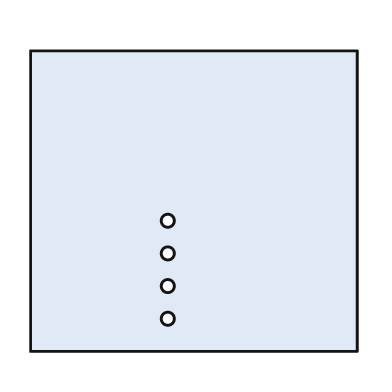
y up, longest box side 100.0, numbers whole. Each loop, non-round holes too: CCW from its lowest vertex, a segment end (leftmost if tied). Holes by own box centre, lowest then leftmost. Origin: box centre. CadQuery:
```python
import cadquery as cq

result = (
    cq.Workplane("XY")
    .moveTo(-50.0, -46.0)
    .lineTo(50.0, -46.0)
    .lineTo(50.0, 46.0)
    .lineTo(-50.0, 46.0)
    .close()
    .moveTo(-8.0, -36.0)
    .circle(2.0)
    .moveTo(-8.0, -26.0)
    .circle(2.0)
    .moveTo(-8.0, -16.0)
    .circle(2.0)
    .moveTo(-8.0, -6.0)
    .circle(2.0)
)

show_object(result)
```